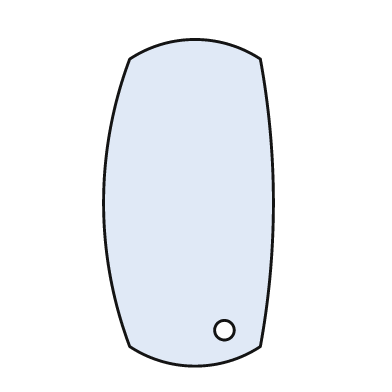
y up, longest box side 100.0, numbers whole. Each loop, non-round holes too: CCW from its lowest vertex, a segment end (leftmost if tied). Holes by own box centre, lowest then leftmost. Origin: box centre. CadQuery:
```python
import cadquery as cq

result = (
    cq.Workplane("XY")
    .moveTo(-18.0, -44.0)
    .threePointArc((2.0, -50.0), (22.0, -44.0))
    .threePointArc((26.0, 0.0), (22.0, 44.0))
    .threePointArc((2.0, 50.0), (-18.0, 44.0))
    .threePointArc((-26.0, 0.0), (-18.0, -44.0))
    .close()
    .moveTo(11.0, -39.0)
    .circle(3.0)
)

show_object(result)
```